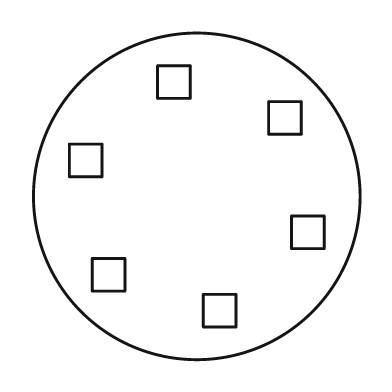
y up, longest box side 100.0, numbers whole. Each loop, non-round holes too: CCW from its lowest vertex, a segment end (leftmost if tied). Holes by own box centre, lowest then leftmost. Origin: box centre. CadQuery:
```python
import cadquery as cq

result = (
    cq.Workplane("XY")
    .moveTo(0.0, 0.0)
    .circle(50.0)
    .moveTo(2.0, -40.0)
    .lineTo(12.0, -40.0)
    .lineTo(12.0, -30.0)
    .lineTo(2.0, -30.0)
    .close()
    .moveTo(-32.0, -29.0)
    .lineTo(-22.0, -29.0)
    .lineTo(-22.0, -19.0)
    .lineTo(-32.0, -19.0)
    .close()
    .moveTo(29.0, -16.0)
    .lineTo(39.0, -16.0)
    .lineTo(39.0, -6.0)
    .lineTo(29.0, -6.0)
    .close()
    .moveTo(-39.0, 6.0)
    .lineTo(-29.0, 6.0)
    .lineTo(-29.0, 16.0)
    .lineTo(-39.0, 16.0)
    .close()
    .moveTo(22.0, 19.0)
    .lineTo(32.0, 19.0)
    .lineTo(32.0, 29.0)
    .lineTo(22.0, 29.0)
    .close()
    .moveTo(-12.0, 30.0)
    .lineTo(-2.0, 30.0)
    .lineTo(-2.0, 40.0)
    .lineTo(-12.0, 40.0)
    .close()
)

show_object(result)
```